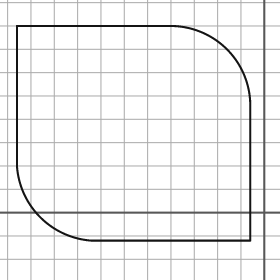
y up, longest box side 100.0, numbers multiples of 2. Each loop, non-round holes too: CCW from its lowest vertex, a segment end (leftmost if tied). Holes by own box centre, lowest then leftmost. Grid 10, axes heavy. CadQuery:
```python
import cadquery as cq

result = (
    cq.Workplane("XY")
    .moveTo(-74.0, -12.0)
    .lineTo(-6.0, -12.0)
    .lineTo(-6.0, 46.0)
    .threePointArc((-16.0, 70.0), (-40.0, 80.0))
    .lineTo(-106.0, 80.0)
    .lineTo(-106.0, 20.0)
    .threePointArc((-96.0, -2.0), (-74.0, -12.0))
    .close()
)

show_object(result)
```